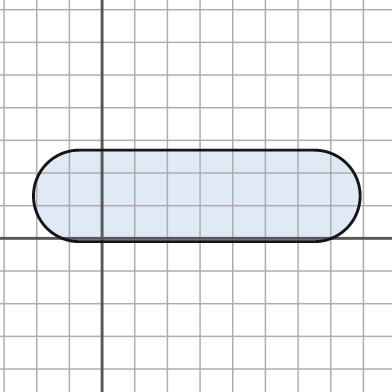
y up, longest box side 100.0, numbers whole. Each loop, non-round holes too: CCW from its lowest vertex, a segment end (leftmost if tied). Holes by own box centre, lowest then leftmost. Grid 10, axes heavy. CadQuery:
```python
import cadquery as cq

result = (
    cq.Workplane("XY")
    .moveTo(-7.0, -1.0)
    .lineTo(65.0, -1.0)
    .threePointArc((79.0, 13.0), (65.0, 27.0))
    .lineTo(-7.0, 27.0)
    .threePointArc((-21.0, 13.0), (-7.0, -1.0))
    .close()
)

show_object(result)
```